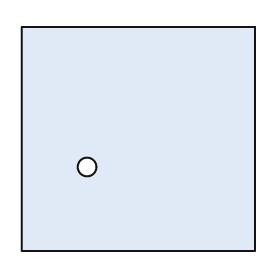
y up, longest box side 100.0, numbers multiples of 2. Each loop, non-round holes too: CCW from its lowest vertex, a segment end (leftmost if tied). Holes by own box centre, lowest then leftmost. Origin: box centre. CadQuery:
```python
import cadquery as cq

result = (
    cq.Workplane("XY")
    .moveTo(-50.0, -48.0)
    .lineTo(50.0, -48.0)
    .lineTo(50.0, 48.0)
    .lineTo(-50.0, 48.0)
    .close()
    .moveTo(-22.0, -12.0)
    .circle(4.0)
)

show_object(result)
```